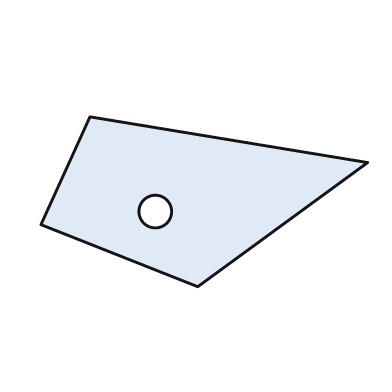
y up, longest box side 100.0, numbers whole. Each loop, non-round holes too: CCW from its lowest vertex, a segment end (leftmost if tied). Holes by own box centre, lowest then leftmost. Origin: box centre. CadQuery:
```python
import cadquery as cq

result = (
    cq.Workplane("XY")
    .moveTo(-2.0, -26.0)
    .lineTo(50.0, 12.0)
    .lineTo(-35.0, 26.0)
    .lineTo(-50.0, -7.0)
    .close()
    .moveTo(-15.0, -3.0)
    .circle(5.0)
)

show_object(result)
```